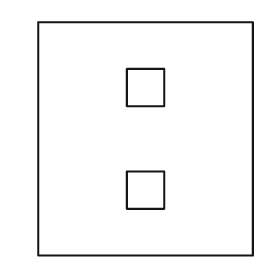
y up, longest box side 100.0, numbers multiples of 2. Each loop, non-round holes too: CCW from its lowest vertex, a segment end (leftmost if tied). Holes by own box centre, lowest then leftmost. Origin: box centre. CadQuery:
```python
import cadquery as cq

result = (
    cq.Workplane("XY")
    .moveTo(-46.0, -50.0)
    .lineTo(46.0, -50.0)
    .lineTo(46.0, 50.0)
    .lineTo(-46.0, 50.0)
    .close()
    .moveTo(-8.0, -30.0)
    .lineTo(8.0, -30.0)
    .lineTo(8.0, -14.0)
    .lineTo(-8.0, -14.0)
    .close()
    .moveTo(-8.0, 14.0)
    .lineTo(8.0, 14.0)
    .lineTo(8.0, 30.0)
    .lineTo(-8.0, 30.0)
    .close()
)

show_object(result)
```